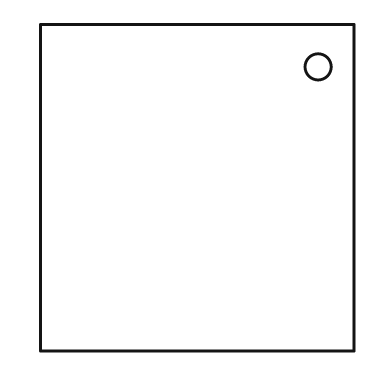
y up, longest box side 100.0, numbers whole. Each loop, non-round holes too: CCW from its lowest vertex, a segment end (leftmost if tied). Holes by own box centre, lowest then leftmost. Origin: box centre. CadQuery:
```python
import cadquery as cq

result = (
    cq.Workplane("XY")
    .moveTo(-48.0, -50.0)
    .lineTo(48.0, -50.0)
    .lineTo(48.0, 50.0)
    .lineTo(-48.0, 50.0)
    .close()
    .moveTo(37.0, 37.0)
    .circle(4.0)
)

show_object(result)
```